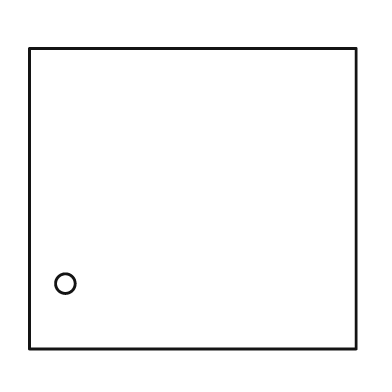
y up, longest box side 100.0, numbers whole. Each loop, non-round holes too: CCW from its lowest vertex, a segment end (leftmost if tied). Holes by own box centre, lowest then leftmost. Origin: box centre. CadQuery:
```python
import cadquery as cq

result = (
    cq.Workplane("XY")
    .moveTo(-50.0, -46.0)
    .lineTo(50.0, -46.0)
    .lineTo(50.0, 46.0)
    .lineTo(-50.0, 46.0)
    .close()
    .moveTo(-39.0, -26.0)
    .circle(3.0)
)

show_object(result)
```